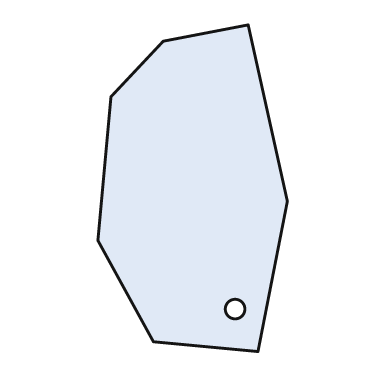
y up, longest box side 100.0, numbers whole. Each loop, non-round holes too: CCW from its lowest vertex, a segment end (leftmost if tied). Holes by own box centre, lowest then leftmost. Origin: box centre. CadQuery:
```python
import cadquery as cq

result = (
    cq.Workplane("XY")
    .moveTo(20.0, -50.0)
    .lineTo(29.0, -4.0)
    .lineTo(17.0, 50.0)
    .lineTo(-9.0, 45.0)
    .lineTo(-25.0, 28.0)
    .lineTo(-29.0, -16.0)
    .lineTo(-12.0, -47.0)
    .close()
    .moveTo(13.0, -37.0)
    .circle(3.0)
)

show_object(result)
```